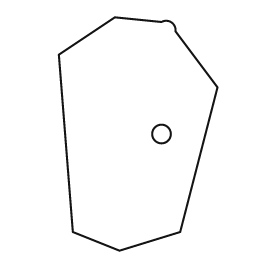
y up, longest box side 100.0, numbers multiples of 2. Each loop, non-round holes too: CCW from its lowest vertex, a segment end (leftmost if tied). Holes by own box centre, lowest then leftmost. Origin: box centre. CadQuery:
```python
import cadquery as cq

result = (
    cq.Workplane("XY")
    .moveTo(-8.0, -50.0)
    .lineTo(18.0, -42.0)
    .lineTo(34.0, 20.0)
    .lineTo(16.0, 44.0)
    .threePointArc((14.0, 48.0), (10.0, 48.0))
    .lineTo(-10.0, 50.0)
    .lineTo(-34.0, 34.0)
    .lineTo(-28.0, -42.0)
    .close()
    .moveTo(10.0, 0.0)
    .circle(4.0)
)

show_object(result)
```